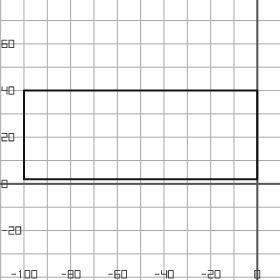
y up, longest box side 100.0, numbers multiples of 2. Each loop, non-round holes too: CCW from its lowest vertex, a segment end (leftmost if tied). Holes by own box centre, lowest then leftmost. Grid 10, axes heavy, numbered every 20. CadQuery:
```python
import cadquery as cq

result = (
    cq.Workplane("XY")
    .moveTo(-100.0, 2.0)
    .lineTo(0.0, 2.0)
    .lineTo(0.0, 40.0)
    .lineTo(-100.0, 40.0)
    .close()
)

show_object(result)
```